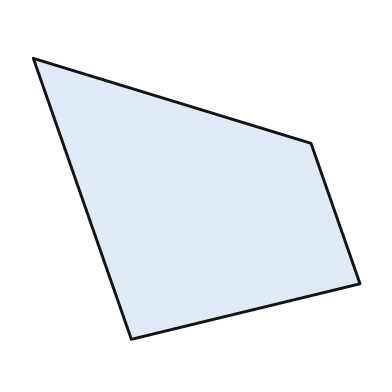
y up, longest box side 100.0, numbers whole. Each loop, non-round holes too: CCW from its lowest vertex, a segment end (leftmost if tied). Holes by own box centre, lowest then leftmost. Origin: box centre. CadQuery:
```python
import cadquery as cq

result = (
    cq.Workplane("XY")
    .moveTo(-20.0, -43.0)
    .lineTo(50.0, -26.0)
    .lineTo(35.0, 17.0)
    .lineTo(-50.0, 43.0)
    .close()
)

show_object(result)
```